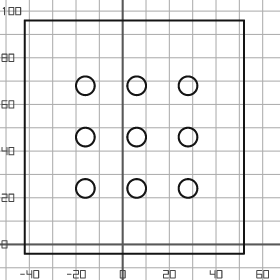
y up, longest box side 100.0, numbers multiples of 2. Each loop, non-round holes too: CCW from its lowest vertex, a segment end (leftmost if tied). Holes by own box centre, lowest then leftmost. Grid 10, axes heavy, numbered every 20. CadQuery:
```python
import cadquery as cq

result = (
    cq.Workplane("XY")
    .moveTo(-42.0, -4.0)
    .lineTo(52.0, -4.0)
    .lineTo(52.0, 96.0)
    .lineTo(-42.0, 96.0)
    .close()
    .moveTo(-16.0, 24.0)
    .circle(4.0)
    .moveTo(6.0, 24.0)
    .circle(4.0)
    .moveTo(28.0, 24.0)
    .circle(4.0)
    .moveTo(-16.0, 46.0)
    .circle(4.0)
    .moveTo(6.0, 46.0)
    .circle(4.0)
    .moveTo(28.0, 46.0)
    .circle(4.0)
    .moveTo(-16.0, 68.0)
    .circle(4.0)
    .moveTo(6.0, 68.0)
    .circle(4.0)
    .moveTo(28.0, 68.0)
    .circle(4.0)
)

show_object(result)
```